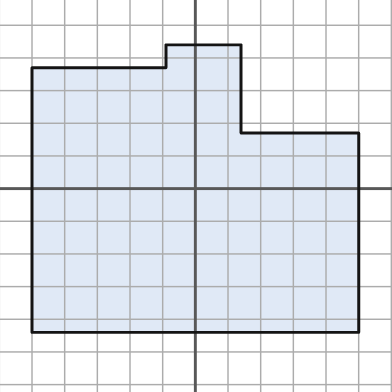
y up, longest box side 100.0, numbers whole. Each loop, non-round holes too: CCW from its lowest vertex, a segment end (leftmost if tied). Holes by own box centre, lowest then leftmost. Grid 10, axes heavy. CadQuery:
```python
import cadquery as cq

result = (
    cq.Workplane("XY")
    .moveTo(-50.0, -44.0)
    .lineTo(50.0, -44.0)
    .lineTo(50.0, 17.0)
    .lineTo(14.0, 17.0)
    .lineTo(14.0, 44.0)
    .lineTo(-9.0, 44.0)
    .lineTo(-9.0, 37.0)
    .lineTo(-50.0, 37.0)
    .close()
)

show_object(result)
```